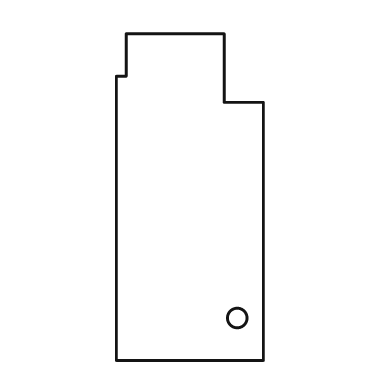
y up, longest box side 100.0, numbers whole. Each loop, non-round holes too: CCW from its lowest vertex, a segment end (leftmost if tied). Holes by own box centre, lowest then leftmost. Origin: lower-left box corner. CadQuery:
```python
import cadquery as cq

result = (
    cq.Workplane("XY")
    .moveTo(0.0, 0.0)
    .lineTo(45.0, 0.0)
    .lineTo(45.0, 79.0)
    .lineTo(33.0, 79.0)
    .lineTo(33.0, 100.0)
    .lineTo(3.0, 100.0)
    .lineTo(3.0, 87.0)
    .lineTo(0.0, 87.0)
    .close()
    .moveTo(37.0, 13.0)
    .circle(3.0)
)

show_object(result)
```